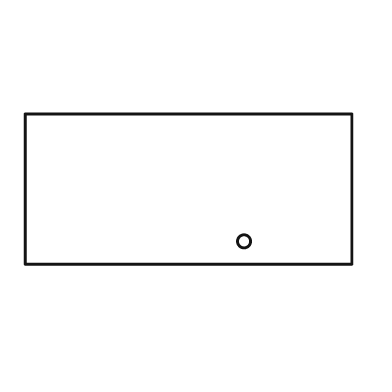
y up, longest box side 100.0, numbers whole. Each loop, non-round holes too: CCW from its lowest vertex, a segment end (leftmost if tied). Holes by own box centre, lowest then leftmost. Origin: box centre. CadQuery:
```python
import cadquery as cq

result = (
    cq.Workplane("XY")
    .moveTo(-50.0, -23.0)
    .lineTo(50.0, -23.0)
    .lineTo(50.0, 23.0)
    .lineTo(-50.0, 23.0)
    .close()
    .moveTo(17.0, -16.0)
    .circle(2.0)
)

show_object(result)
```